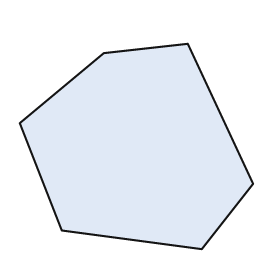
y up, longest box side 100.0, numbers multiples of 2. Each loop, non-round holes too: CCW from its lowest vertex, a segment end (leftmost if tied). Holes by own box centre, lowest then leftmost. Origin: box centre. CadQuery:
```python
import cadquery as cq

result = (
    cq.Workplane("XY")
    .moveTo(28.0, -44.0)
    .lineTo(50.0, -16.0)
    .lineTo(22.0, 44.0)
    .lineTo(-14.0, 40.0)
    .lineTo(-50.0, 10.0)
    .lineTo(-32.0, -36.0)
    .close()
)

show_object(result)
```